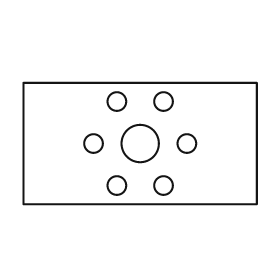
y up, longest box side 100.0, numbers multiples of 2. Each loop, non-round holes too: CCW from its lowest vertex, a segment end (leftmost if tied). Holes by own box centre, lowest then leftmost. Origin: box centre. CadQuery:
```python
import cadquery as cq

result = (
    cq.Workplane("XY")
    .moveTo(-50.0, -26.0)
    .lineTo(50.0, -26.0)
    .lineTo(50.0, 26.0)
    .lineTo(-50.0, 26.0)
    .close()
    .moveTo(-10.0, -18.0)
    .circle(4.0)
    .moveTo(10.0, -18.0)
    .circle(4.0)
    .moveTo(-20.0, 0.0)
    .circle(4.0)
    .moveTo(0.0, 0.0)
    .circle(8.0)
    .moveTo(20.0, 0.0)
    .circle(4.0)
    .moveTo(-10.0, 18.0)
    .circle(4.0)
    .moveTo(10.0, 18.0)
    .circle(4.0)
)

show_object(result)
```